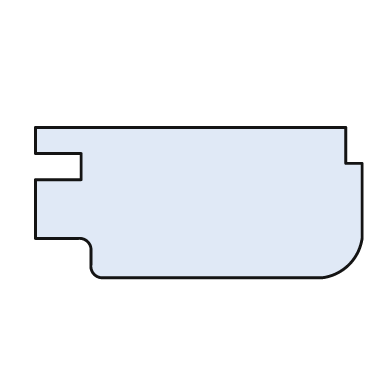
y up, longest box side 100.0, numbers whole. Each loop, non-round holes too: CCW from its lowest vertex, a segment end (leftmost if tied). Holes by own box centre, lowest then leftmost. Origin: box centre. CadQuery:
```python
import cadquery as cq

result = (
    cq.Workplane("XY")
    .moveTo(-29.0, -23.0)
    .lineTo(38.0, -23.0)
    .threePointArc((46.0, -19.0), (50.0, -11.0))
    .lineTo(50.0, 12.0)
    .lineTo(45.0, 12.0)
    .lineTo(45.0, 23.0)
    .lineTo(-50.0, 23.0)
    .lineTo(-50.0, 15.0)
    .lineTo(-36.0, 15.0)
    .lineTo(-36.0, 7.0)
    .lineTo(-50.0, 7.0)
    .lineTo(-50.0, -11.0)
    .lineTo(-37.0, -11.0)
    .threePointArc((-34.0, -12.0), (-33.0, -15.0))
    .lineTo(-33.0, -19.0)
    .threePointArc((-32.0, -22.0), (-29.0, -23.0))
    .close()
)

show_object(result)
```